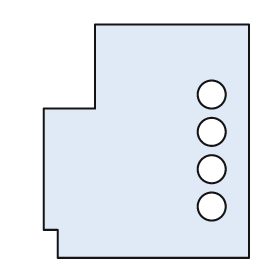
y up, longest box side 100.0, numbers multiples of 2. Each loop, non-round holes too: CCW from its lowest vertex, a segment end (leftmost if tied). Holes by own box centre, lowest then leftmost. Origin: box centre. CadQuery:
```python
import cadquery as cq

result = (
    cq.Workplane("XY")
    .moveTo(-38.0, -50.0)
    .lineTo(44.0, -50.0)
    .lineTo(44.0, 50.0)
    .lineTo(-22.0, 50.0)
    .lineTo(-22.0, 14.0)
    .lineTo(-44.0, 14.0)
    .lineTo(-44.0, -38.0)
    .lineTo(-38.0, -38.0)
    .close()
    .moveTo(28.0, -28.0)
    .circle(6.0)
    .moveTo(28.0, -12.0)
    .circle(6.0)
    .moveTo(28.0, 4.0)
    .circle(6.0)
    .moveTo(28.0, 20.0)
    .circle(6.0)
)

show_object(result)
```